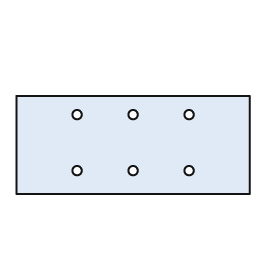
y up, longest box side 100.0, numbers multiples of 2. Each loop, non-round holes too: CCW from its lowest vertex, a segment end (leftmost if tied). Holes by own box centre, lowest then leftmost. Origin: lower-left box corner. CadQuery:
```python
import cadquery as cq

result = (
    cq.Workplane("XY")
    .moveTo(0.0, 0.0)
    .lineTo(100.0, 0.0)
    .lineTo(100.0, 42.0)
    .lineTo(0.0, 42.0)
    .close()
    .moveTo(26.0, 10.0)
    .circle(2.0)
    .moveTo(50.0, 10.0)
    .circle(2.0)
    .moveTo(74.0, 10.0)
    .circle(2.0)
    .moveTo(26.0, 34.0)
    .circle(2.0)
    .moveTo(50.0, 34.0)
    .circle(2.0)
    .moveTo(74.0, 34.0)
    .circle(2.0)
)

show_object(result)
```